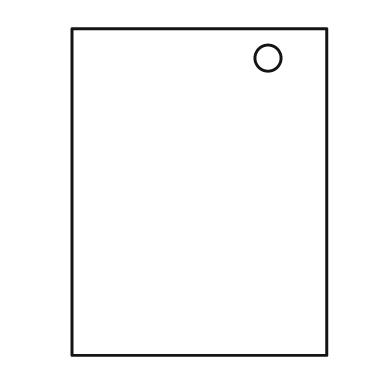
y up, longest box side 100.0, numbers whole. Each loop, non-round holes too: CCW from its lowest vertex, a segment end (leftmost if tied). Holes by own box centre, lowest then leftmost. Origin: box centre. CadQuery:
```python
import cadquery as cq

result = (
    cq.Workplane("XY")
    .moveTo(-39.0, -50.0)
    .lineTo(39.0, -50.0)
    .lineTo(39.0, 50.0)
    .lineTo(-39.0, 50.0)
    .close()
    .moveTo(21.0, 41.0)
    .circle(4.0)
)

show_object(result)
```